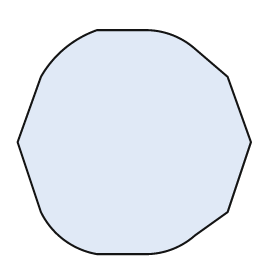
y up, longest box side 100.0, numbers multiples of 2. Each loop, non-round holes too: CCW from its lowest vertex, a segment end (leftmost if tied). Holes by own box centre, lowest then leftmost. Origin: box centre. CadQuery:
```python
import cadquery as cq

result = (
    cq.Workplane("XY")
    .moveTo(-16.0, -48.0)
    .lineTo(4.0, -48.0)
    .threePointArc((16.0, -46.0), (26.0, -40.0))
    .lineTo(40.0, -30.0)
    .lineTo(50.0, 0.0)
    .lineTo(40.0, 28.0)
    .lineTo(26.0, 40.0)
    .threePointArc((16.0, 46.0), (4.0, 48.0))
    .lineTo(-16.0, 48.0)
    .threePointArc((-30.0, 40.0), (-40.0, 28.0))
    .lineTo(-50.0, 0.0)
    .lineTo(-40.0, -30.0)
    .threePointArc((-30.0, -42.0), (-16.0, -48.0))
    .close()
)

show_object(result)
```